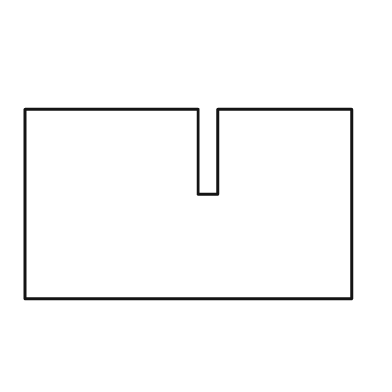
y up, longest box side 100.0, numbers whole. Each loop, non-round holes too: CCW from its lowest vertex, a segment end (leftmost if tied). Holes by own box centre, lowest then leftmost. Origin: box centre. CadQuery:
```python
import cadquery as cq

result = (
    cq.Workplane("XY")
    .moveTo(-50.0, -29.0)
    .lineTo(50.0, -29.0)
    .lineTo(50.0, 29.0)
    .lineTo(9.0, 29.0)
    .lineTo(9.0, 3.0)
    .lineTo(3.0, 3.0)
    .lineTo(3.0, 29.0)
    .lineTo(-50.0, 29.0)
    .close()
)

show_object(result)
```